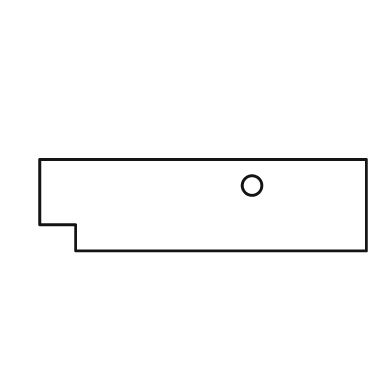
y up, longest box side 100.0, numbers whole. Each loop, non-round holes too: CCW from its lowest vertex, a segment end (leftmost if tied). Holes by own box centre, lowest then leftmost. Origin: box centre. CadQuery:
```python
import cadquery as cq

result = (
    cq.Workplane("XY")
    .moveTo(-39.0, -14.0)
    .lineTo(50.0, -14.0)
    .lineTo(50.0, 14.0)
    .lineTo(-50.0, 14.0)
    .lineTo(-50.0, -6.0)
    .lineTo(-39.0, -6.0)
    .close()
    .moveTo(15.0, 6.0)
    .circle(3.0)
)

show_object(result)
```